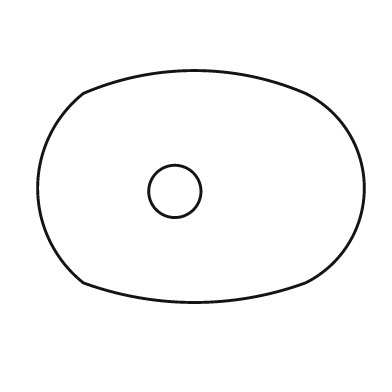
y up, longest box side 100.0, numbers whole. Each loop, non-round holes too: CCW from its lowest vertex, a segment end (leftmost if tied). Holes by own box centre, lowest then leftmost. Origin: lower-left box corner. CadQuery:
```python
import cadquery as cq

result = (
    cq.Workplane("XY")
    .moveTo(14.0, 6.0)
    .threePointArc((48.0, 0.0), (82.0, 6.0))
    .threePointArc((100.0, 35.0), (82.0, 64.0))
    .threePointArc((48.0, 71.0), (14.0, 64.0))
    .threePointArc((0.0, 35.0), (14.0, 6.0))
    .close()
    .moveTo(42.0, 34.0)
    .circle(8.0)
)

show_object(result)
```